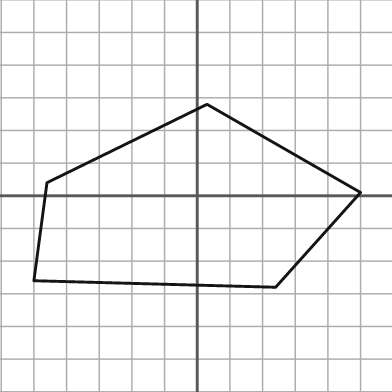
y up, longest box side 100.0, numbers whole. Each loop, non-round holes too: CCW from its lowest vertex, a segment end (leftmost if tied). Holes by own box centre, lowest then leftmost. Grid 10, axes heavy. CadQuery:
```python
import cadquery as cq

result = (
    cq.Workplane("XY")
    .moveTo(24.0, -28.0)
    .lineTo(50.0, 1.0)
    .lineTo(3.0, 28.0)
    .lineTo(-46.0, 4.0)
    .lineTo(-50.0, -26.0)
    .close()
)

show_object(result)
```